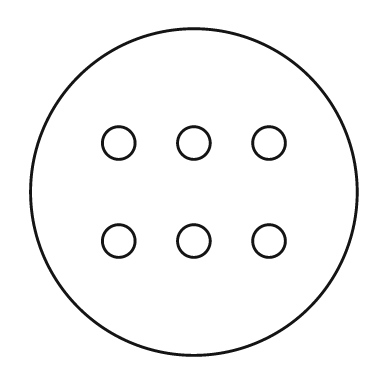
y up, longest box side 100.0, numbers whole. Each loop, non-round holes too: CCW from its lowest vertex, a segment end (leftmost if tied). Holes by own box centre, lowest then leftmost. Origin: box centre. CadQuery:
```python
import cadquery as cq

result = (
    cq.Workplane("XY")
    .moveTo(0.0, 0.0)
    .circle(50.0)
    .moveTo(-23.0, -15.0)
    .circle(5.0)
    .moveTo(0.0, -15.0)
    .circle(5.0)
    .moveTo(23.0, -15.0)
    .circle(5.0)
    .moveTo(-23.0, 15.0)
    .circle(5.0)
    .moveTo(0.0, 15.0)
    .circle(5.0)
    .moveTo(23.0, 15.0)
    .circle(5.0)
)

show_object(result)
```